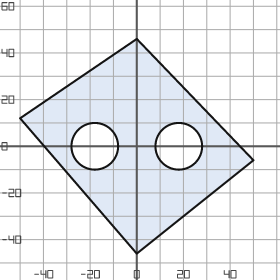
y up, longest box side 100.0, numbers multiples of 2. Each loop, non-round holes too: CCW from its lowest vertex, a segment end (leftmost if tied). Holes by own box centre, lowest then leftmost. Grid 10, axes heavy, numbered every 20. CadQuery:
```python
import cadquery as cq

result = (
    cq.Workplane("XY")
    .moveTo(0.0, -46.0)
    .lineTo(50.0, -6.0)
    .lineTo(0.0, 46.0)
    .lineTo(-50.0, 12.0)
    .close()
    .moveTo(-18.0, 0.0)
    .circle(10.0)
    .moveTo(18.0, 0.0)
    .circle(10.0)
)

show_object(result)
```